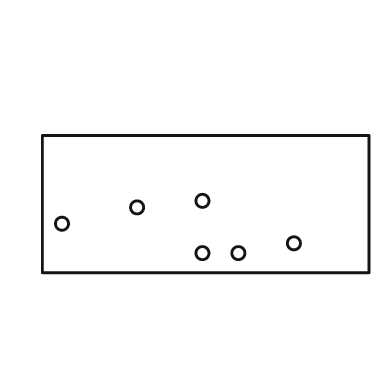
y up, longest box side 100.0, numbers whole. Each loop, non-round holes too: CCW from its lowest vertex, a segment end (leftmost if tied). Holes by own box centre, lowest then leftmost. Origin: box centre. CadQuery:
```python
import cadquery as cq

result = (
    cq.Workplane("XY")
    .moveTo(-50.0, -21.0)
    .lineTo(50.0, -21.0)
    .lineTo(50.0, 21.0)
    .lineTo(-50.0, 21.0)
    .close()
    .moveTo(-1.0, -15.0)
    .circle(2.0)
    .moveTo(10.0, -15.0)
    .circle(2.0)
    .moveTo(27.0, -12.0)
    .circle(2.0)
    .moveTo(-44.0, -6.0)
    .circle(2.0)
    .moveTo(-21.0, -1.0)
    .circle(2.0)
    .moveTo(-1.0, 1.0)
    .circle(2.0)
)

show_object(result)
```